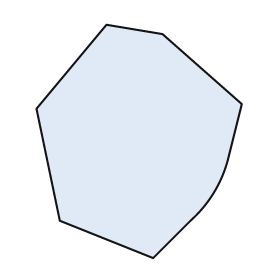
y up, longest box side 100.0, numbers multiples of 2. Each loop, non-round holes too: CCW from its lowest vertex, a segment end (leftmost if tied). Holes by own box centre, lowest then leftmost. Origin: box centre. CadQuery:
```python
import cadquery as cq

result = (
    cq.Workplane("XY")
    .moveTo(6.0, -50.0)
    .lineTo(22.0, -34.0)
    .threePointArc((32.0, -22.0), (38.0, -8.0))
    .lineTo(44.0, 16.0)
    .lineTo(10.0, 46.0)
    .lineTo(-14.0, 50.0)
    .lineTo(-44.0, 14.0)
    .lineTo(-34.0, -34.0)
    .close()
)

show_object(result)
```